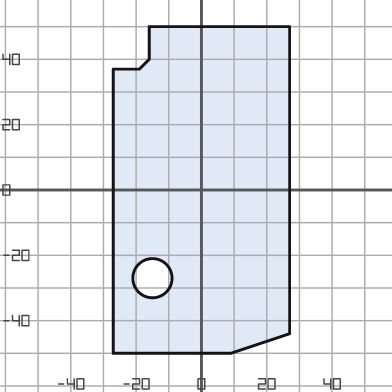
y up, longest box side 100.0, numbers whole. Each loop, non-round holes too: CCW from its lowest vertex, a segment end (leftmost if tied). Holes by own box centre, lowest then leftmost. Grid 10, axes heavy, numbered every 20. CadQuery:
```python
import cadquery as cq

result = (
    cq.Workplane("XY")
    .moveTo(-27.0, -50.0)
    .lineTo(9.0, -50.0)
    .lineTo(27.0, -44.0)
    .lineTo(27.0, 50.0)
    .lineTo(-16.0, 50.0)
    .lineTo(-16.0, 40.0)
    .lineTo(-19.0, 37.0)
    .lineTo(-27.0, 37.0)
    .close()
    .moveTo(-15.0, -27.0)
    .circle(6.0)
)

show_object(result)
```